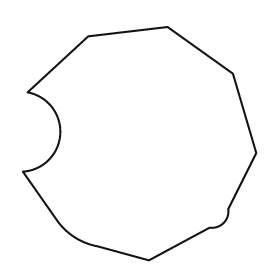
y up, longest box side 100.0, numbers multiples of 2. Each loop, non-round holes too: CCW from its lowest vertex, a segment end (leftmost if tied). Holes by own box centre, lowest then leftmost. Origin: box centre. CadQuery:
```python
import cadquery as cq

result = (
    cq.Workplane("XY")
    .moveTo(4.0, -50.0)
    .lineTo(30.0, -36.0)
    .threePointArc((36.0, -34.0), (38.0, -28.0))
    .lineTo(50.0, -4.0)
    .lineTo(40.0, 30.0)
    .lineTo(12.0, 50.0)
    .lineTo(-22.0, 46.0)
    .lineTo(-48.0, 22.0)
    .threePointArc((-34.0, 4.0), (-50.0, -12.0))
    .lineTo(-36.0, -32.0)
    .threePointArc((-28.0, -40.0), (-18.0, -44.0))
    .close()
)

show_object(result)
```